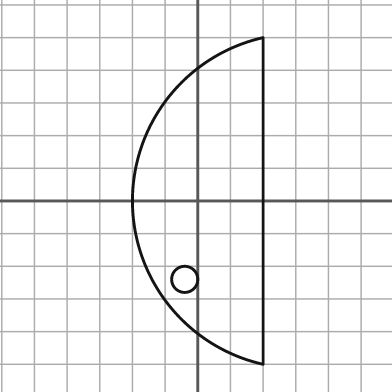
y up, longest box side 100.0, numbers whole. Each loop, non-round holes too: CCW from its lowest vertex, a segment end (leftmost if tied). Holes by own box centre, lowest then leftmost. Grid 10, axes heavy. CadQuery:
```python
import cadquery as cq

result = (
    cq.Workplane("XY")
    .moveTo(20.0, -50.0)
    .lineTo(20.0, 50.0)
    .threePointArc((-20.0, 0.0), (20.0, -50.0))
    .close()
    .moveTo(-4.0, -24.0)
    .circle(4.0)
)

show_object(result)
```